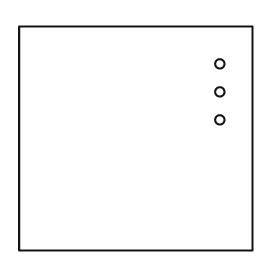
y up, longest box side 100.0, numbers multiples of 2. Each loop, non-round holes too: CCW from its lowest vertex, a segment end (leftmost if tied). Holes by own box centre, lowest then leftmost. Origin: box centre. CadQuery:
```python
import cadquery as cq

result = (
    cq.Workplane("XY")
    .moveTo(-50.0, -48.0)
    .lineTo(50.0, -48.0)
    .lineTo(50.0, 48.0)
    .lineTo(-50.0, 48.0)
    .close()
    .moveTo(36.0, 8.0)
    .circle(2.0)
    .moveTo(36.0, 20.0)
    .circle(2.0)
    .moveTo(36.0, 32.0)
    .circle(2.0)
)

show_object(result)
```